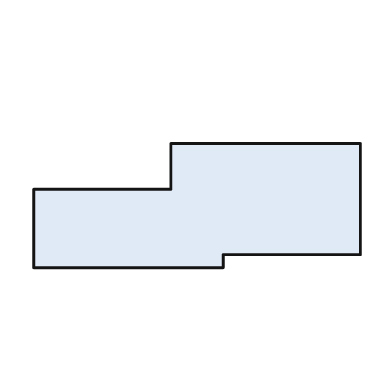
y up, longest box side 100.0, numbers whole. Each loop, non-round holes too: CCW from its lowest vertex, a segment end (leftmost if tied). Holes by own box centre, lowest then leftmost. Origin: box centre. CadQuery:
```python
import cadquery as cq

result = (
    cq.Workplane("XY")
    .moveTo(-50.0, -19.0)
    .lineTo(8.0, -19.0)
    .lineTo(8.0, -15.0)
    .lineTo(50.0, -15.0)
    .lineTo(50.0, 19.0)
    .lineTo(-8.0, 19.0)
    .lineTo(-8.0, 5.0)
    .lineTo(-50.0, 5.0)
    .close()
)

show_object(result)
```